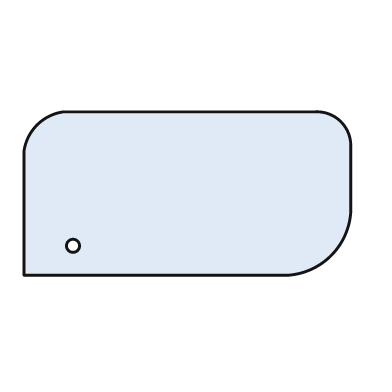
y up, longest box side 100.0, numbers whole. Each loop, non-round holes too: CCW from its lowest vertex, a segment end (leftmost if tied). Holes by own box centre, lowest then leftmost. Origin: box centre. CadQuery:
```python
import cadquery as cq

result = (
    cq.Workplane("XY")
    .moveTo(-50.0, -25.0)
    .lineTo(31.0, -25.0)
    .threePointArc((44.0, -19.0), (50.0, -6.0))
    .lineTo(50.0, 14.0)
    .threePointArc((47.0, 22.0), (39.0, 25.0))
    .lineTo(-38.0, 25.0)
    .threePointArc((-46.0, 21.0), (-50.0, 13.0))
    .close()
    .moveTo(-35.0, -16.0)
    .circle(2.0)
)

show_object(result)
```